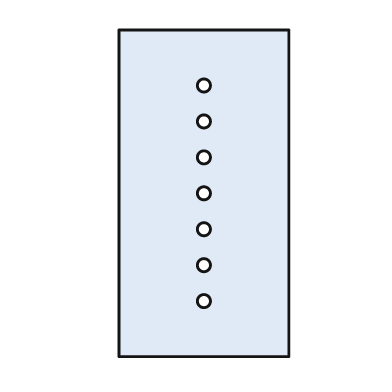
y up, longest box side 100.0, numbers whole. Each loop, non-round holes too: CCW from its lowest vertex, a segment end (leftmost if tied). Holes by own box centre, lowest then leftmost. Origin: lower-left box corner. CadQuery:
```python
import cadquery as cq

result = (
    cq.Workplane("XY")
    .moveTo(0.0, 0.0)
    .lineTo(52.0, 0.0)
    .lineTo(52.0, 100.0)
    .lineTo(0.0, 100.0)
    .close()
    .moveTo(26.0, 17.0)
    .circle(2.0)
    .moveTo(26.0, 28.0)
    .circle(2.0)
    .moveTo(26.0, 39.0)
    .circle(2.0)
    .moveTo(26.0, 50.0)
    .circle(2.0)
    .moveTo(26.0, 61.0)
    .circle(2.0)
    .moveTo(26.0, 72.0)
    .circle(2.0)
    .moveTo(26.0, 83.0)
    .circle(2.0)
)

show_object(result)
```